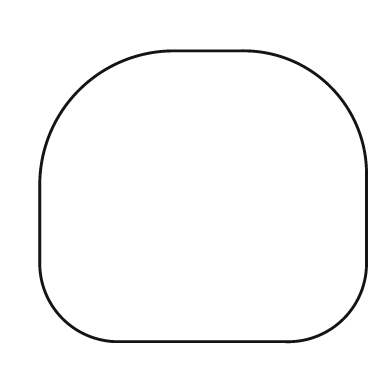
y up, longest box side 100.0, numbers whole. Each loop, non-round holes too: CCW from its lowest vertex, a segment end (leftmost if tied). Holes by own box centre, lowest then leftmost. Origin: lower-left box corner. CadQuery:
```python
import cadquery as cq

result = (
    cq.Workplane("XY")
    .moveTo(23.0, 0.0)
    .lineTo(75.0, 0.0)
    .threePointArc((93.0, 7.0), (100.0, 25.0))
    .lineTo(100.0, 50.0)
    .threePointArc((89.0, 78.0), (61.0, 89.0))
    .lineTo(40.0, 89.0)
    .threePointArc((12.0, 77.0), (0.0, 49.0))
    .lineTo(0.0, 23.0)
    .threePointArc((7.0, 7.0), (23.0, 0.0))
    .close()
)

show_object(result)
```